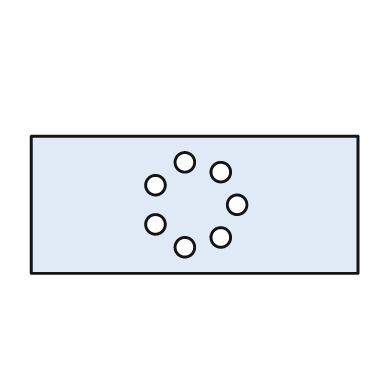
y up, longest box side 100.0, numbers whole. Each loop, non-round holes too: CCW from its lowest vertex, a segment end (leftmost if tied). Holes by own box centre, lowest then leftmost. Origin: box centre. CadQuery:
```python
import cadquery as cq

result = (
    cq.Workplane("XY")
    .moveTo(-50.0, -21.0)
    .lineTo(50.0, -21.0)
    .lineTo(50.0, 21.0)
    .lineTo(-50.0, 21.0)
    .close()
    .moveTo(-3.0, -13.0)
    .circle(3.0)
    .moveTo(8.0, -10.0)
    .circle(3.0)
    .moveTo(-12.0, -6.0)
    .circle(3.0)
    .moveTo(13.0, 0.0)
    .circle(3.0)
    .moveTo(-12.0, 6.0)
    .circle(3.0)
    .moveTo(8.0, 10.0)
    .circle(3.0)
    .moveTo(-3.0, 13.0)
    .circle(3.0)
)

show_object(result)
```